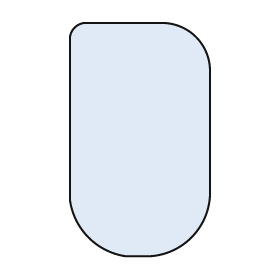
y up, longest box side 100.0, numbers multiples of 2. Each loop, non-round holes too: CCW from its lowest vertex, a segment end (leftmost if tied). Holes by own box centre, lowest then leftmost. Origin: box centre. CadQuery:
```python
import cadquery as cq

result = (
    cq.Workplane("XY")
    .moveTo(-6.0, -50.0)
    .lineTo(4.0, -50.0)
    .threePointArc((22.0, -42.0), (30.0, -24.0))
    .lineTo(30.0, 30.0)
    .threePointArc((24.0, 44.0), (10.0, 50.0))
    .lineTo(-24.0, 50.0)
    .threePointArc((-28.0, 48.0), (-30.0, 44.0))
    .lineTo(-30.0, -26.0)
    .threePointArc((-22.0, -42.0), (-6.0, -50.0))
    .close()
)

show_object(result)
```